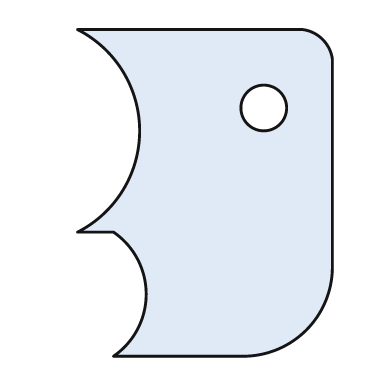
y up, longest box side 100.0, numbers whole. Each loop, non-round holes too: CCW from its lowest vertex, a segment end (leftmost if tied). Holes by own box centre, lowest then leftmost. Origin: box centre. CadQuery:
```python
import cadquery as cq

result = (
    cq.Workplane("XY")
    .moveTo(-28.0, -50.0)
    .lineTo(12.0, -50.0)
    .threePointArc((31.0, -42.0), (39.0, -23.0))
    .lineTo(39.0, 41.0)
    .threePointArc((36.0, 47.0), (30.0, 50.0))
    .lineTo(-39.0, 50.0)
    .threePointArc((-20.0, 19.0), (-39.0, -12.0))
    .lineTo(-28.0, -12.0)
    .threePointArc((-18.0, -31.0), (-28.0, -50.0))
    .close()
    .moveTo(18.0, 26.0)
    .circle(7.0)
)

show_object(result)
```